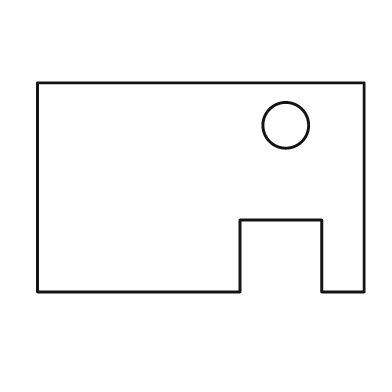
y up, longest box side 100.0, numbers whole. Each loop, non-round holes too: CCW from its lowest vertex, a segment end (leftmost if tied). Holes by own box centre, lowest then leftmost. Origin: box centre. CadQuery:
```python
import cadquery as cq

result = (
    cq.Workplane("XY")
    .moveTo(-50.0, -32.0)
    .lineTo(12.0, -32.0)
    .lineTo(12.0, -10.0)
    .lineTo(37.0, -10.0)
    .lineTo(37.0, -32.0)
    .lineTo(50.0, -32.0)
    .lineTo(50.0, 32.0)
    .lineTo(-50.0, 32.0)
    .close()
    .moveTo(26.0, 19.0)
    .circle(7.0)
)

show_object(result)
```